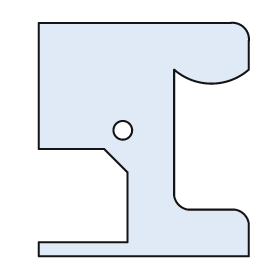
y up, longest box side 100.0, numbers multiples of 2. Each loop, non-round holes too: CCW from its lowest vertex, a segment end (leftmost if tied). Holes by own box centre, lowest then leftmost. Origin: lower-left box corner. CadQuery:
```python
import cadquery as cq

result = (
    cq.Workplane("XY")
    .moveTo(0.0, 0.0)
    .lineTo(90.0, 0.0)
    .lineTo(90.0, 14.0)
    .threePointArc((88.0, 18.0), (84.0, 20.0))
    .lineTo(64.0, 20.0)
    .threePointArc((60.0, 22.0), (58.0, 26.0))
    .lineTo(58.0, 80.0)
    .threePointArc((74.0, 74.0), (90.0, 80.0))
    .lineTo(90.0, 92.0)
    .threePointArc((88.0, 98.0), (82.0, 100.0))
    .lineTo(0.0, 100.0)
    .lineTo(0.0, 46.0)
    .lineTo(28.0, 46.0)
    .lineTo(38.0, 36.0)
    .lineTo(38.0, 6.0)
    .lineTo(0.0, 6.0)
    .close()
    .moveTo(36.0, 54.0)
    .circle(4.0)
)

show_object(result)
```